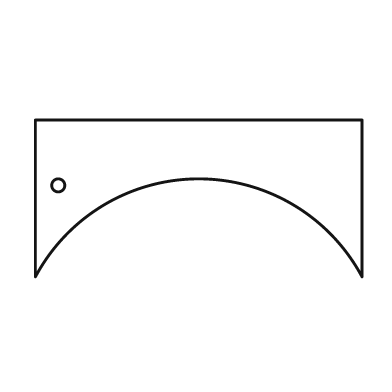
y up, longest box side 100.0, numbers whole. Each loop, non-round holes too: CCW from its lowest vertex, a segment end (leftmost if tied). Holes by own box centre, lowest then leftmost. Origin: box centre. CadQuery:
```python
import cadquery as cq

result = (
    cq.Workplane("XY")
    .moveTo(-50.0, -24.0)
    .threePointArc((0.0, 6.0), (50.0, -24.0))
    .lineTo(50.0, 24.0)
    .lineTo(-50.0, 24.0)
    .close()
    .moveTo(-43.0, 4.0)
    .circle(2.0)
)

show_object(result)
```